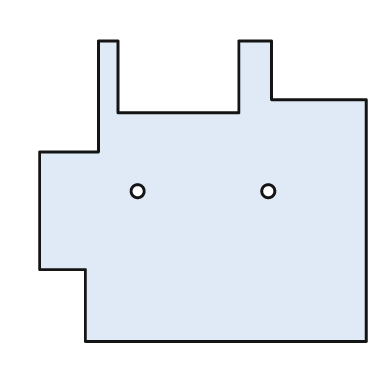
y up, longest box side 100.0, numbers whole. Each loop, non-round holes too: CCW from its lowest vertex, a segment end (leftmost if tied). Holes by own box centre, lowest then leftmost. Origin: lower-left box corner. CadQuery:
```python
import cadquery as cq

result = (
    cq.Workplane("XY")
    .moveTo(14.0, 0.0)
    .lineTo(100.0, 0.0)
    .lineTo(100.0, 74.0)
    .lineTo(71.0, 74.0)
    .lineTo(71.0, 92.0)
    .lineTo(61.0, 92.0)
    .lineTo(61.0, 70.0)
    .lineTo(24.0, 70.0)
    .lineTo(24.0, 92.0)
    .lineTo(18.0, 92.0)
    .lineTo(18.0, 58.0)
    .lineTo(0.0, 58.0)
    .lineTo(0.0, 22.0)
    .lineTo(14.0, 22.0)
    .close()
    .moveTo(30.0, 46.0)
    .circle(2.0)
    .moveTo(70.0, 46.0)
    .circle(2.0)
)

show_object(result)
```